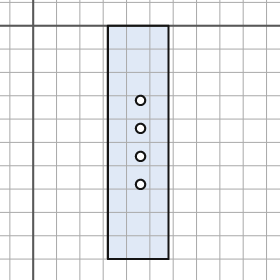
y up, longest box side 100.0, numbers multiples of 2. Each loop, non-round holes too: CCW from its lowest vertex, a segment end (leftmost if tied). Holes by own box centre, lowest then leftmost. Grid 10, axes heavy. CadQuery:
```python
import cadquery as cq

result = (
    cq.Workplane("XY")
    .moveTo(32.0, -100.0)
    .lineTo(58.0, -100.0)
    .lineTo(58.0, 0.0)
    .lineTo(32.0, 0.0)
    .close()
    .moveTo(46.0, -68.0)
    .circle(2.0)
    .moveTo(46.0, -56.0)
    .circle(2.0)
    .moveTo(46.0, -44.0)
    .circle(2.0)
    .moveTo(46.0, -32.0)
    .circle(2.0)
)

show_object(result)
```